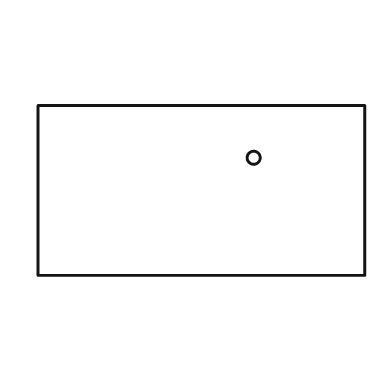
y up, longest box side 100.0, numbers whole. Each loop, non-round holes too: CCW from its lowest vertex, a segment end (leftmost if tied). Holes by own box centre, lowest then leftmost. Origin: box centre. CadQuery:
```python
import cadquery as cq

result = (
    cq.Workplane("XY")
    .moveTo(-50.0, -26.0)
    .lineTo(50.0, -26.0)
    .lineTo(50.0, 26.0)
    .lineTo(-50.0, 26.0)
    .close()
    .moveTo(16.0, 10.0)
    .circle(2.0)
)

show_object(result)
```